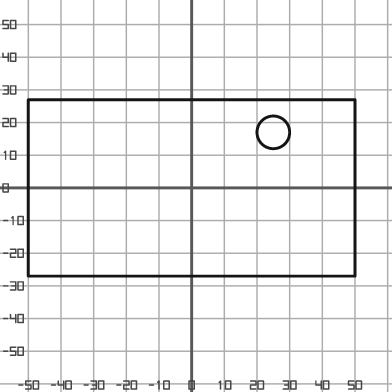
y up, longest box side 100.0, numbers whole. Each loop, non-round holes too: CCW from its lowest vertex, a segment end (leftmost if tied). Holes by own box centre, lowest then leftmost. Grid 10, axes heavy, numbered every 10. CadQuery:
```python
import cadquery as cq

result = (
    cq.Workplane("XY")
    .moveTo(-50.0, -27.0)
    .lineTo(50.0, -27.0)
    .lineTo(50.0, 27.0)
    .lineTo(-50.0, 27.0)
    .close()
    .moveTo(25.0, 17.0)
    .circle(5.0)
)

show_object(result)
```